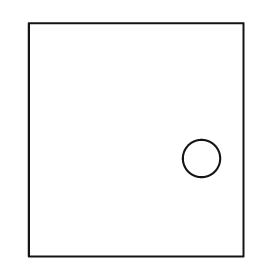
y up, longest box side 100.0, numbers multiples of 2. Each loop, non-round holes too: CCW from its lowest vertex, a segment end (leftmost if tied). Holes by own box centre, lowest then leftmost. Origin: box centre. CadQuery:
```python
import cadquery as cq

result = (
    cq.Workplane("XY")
    .moveTo(-46.0, -50.0)
    .lineTo(46.0, -50.0)
    .lineTo(46.0, 50.0)
    .lineTo(-46.0, 50.0)
    .close()
    .moveTo(28.0, -8.0)
    .circle(8.0)
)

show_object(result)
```